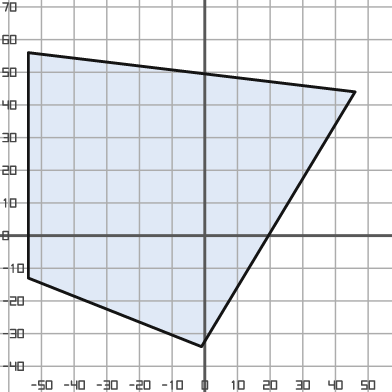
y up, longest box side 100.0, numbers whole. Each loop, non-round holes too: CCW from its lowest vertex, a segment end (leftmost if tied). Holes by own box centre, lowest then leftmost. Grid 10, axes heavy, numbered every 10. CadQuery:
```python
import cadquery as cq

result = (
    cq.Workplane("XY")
    .moveTo(-1.0, -34.0)
    .lineTo(46.0, 44.0)
    .lineTo(-54.0, 56.0)
    .lineTo(-54.0, -13.0)
    .close()
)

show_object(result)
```